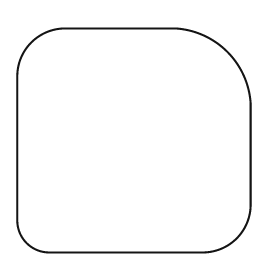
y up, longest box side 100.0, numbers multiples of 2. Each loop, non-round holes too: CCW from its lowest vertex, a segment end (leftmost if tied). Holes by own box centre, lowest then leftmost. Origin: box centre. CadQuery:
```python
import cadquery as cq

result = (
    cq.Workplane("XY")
    .moveTo(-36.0, -48.0)
    .lineTo(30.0, -48.0)
    .threePointArc((44.0, -42.0), (50.0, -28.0))
    .lineTo(50.0, 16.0)
    .threePointArc((40.0, 38.0), (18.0, 48.0))
    .lineTo(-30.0, 48.0)
    .threePointArc((-44.0, 42.0), (-50.0, 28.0))
    .lineTo(-50.0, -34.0)
    .threePointArc((-46.0, -44.0), (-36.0, -48.0))
    .close()
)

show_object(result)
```